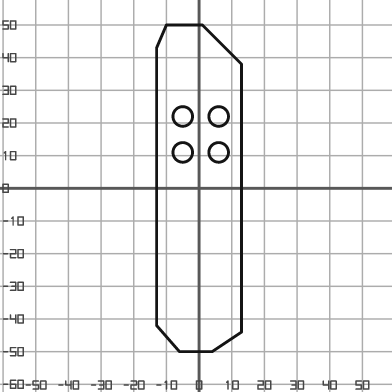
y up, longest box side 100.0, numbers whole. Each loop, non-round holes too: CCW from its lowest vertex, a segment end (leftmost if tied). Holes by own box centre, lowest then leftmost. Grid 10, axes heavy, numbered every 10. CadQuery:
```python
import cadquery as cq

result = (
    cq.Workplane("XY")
    .moveTo(-6.0, -50.0)
    .lineTo(4.0, -50.0)
    .lineTo(13.0, -44.0)
    .lineTo(13.0, 38.0)
    .lineTo(1.0, 50.0)
    .lineTo(-10.0, 50.0)
    .lineTo(-13.0, 43.0)
    .lineTo(-13.0, -42.0)
    .close()
    .moveTo(-5.0, 11.0)
    .circle(3.0)
    .moveTo(6.0, 11.0)
    .circle(3.0)
    .moveTo(-5.0, 22.0)
    .circle(3.0)
    .moveTo(6.0, 22.0)
    .circle(3.0)
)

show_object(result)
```